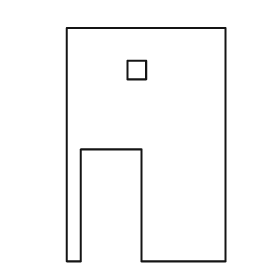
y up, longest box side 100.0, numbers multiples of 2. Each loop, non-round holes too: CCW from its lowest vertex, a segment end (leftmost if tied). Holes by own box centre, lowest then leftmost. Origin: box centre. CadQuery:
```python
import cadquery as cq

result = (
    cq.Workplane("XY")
    .moveTo(-34.0, -50.0)
    .lineTo(-28.0, -50.0)
    .lineTo(-28.0, -2.0)
    .lineTo(-2.0, -2.0)
    .lineTo(-2.0, -50.0)
    .lineTo(34.0, -50.0)
    .lineTo(34.0, 50.0)
    .lineTo(-34.0, 50.0)
    .close()
    .moveTo(-8.0, 28.0)
    .lineTo(0.0, 28.0)
    .lineTo(0.0, 36.0)
    .lineTo(-8.0, 36.0)
    .close()
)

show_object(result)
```